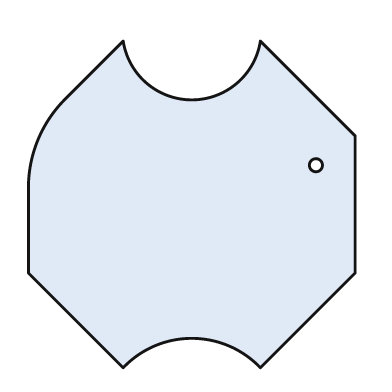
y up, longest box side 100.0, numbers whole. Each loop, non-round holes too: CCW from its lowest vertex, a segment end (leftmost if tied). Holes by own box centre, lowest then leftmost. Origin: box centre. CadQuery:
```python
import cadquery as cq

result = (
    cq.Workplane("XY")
    .moveTo(-21.0, -50.0)
    .threePointArc((0.0, -41.0), (21.0, -50.0))
    .lineTo(50.0, -21.0)
    .lineTo(50.0, 21.0)
    .lineTo(21.0, 50.0)
    .threePointArc((0.0, 32.0), (-21.0, 50.0))
    .lineTo(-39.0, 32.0)
    .threePointArc((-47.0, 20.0), (-50.0, 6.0))
    .lineTo(-50.0, -21.0)
    .close()
    .moveTo(38.0, 12.0)
    .circle(2.0)
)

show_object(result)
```